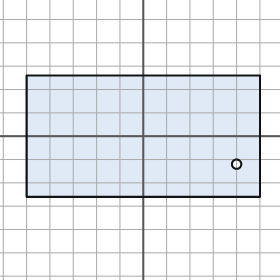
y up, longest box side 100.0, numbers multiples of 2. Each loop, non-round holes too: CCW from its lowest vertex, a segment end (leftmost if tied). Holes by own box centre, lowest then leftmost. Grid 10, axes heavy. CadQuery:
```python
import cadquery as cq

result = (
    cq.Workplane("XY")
    .moveTo(-50.0, -26.0)
    .lineTo(50.0, -26.0)
    .lineTo(50.0, 26.0)
    .lineTo(-50.0, 26.0)
    .close()
    .moveTo(40.0, -12.0)
    .circle(2.0)
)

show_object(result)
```